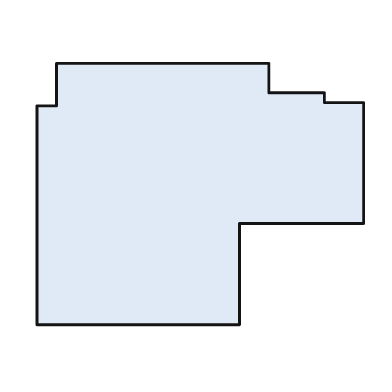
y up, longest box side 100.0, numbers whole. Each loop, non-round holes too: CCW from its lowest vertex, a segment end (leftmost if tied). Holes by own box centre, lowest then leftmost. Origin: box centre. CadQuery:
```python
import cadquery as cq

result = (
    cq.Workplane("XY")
    .moveTo(-50.0, -40.0)
    .lineTo(12.0, -40.0)
    .lineTo(12.0, -9.0)
    .lineTo(50.0, -9.0)
    .lineTo(50.0, 28.0)
    .lineTo(38.0, 28.0)
    .lineTo(38.0, 31.0)
    .lineTo(21.0, 31.0)
    .lineTo(21.0, 40.0)
    .lineTo(-44.0, 40.0)
    .lineTo(-44.0, 27.0)
    .lineTo(-50.0, 27.0)
    .close()
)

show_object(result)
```